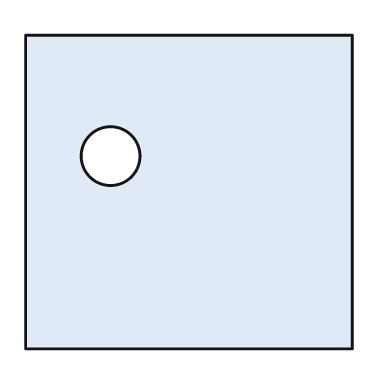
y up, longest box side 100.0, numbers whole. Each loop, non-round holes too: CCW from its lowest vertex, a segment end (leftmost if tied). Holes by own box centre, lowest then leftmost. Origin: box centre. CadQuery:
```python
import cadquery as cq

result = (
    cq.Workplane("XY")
    .moveTo(-50.0, -48.0)
    .lineTo(50.0, -48.0)
    .lineTo(50.0, 48.0)
    .lineTo(-50.0, 48.0)
    .close()
    .moveTo(-24.0, 11.0)
    .circle(9.0)
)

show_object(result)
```